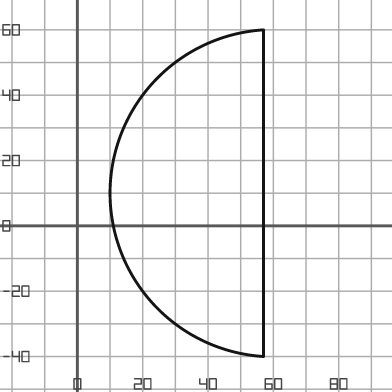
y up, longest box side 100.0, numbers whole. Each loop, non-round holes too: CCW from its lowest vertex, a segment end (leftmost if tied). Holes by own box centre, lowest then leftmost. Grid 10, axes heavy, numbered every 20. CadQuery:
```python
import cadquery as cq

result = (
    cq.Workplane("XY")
    .moveTo(57.0, -40.0)
    .lineTo(57.0, 60.0)
    .threePointArc((10.0, 10.0), (57.0, -40.0))
    .close()
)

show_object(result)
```